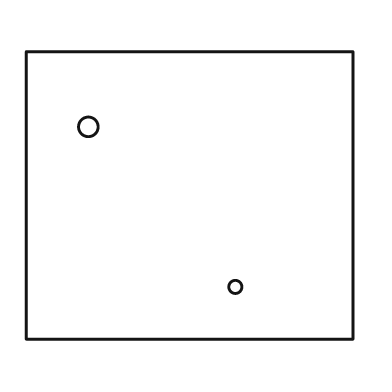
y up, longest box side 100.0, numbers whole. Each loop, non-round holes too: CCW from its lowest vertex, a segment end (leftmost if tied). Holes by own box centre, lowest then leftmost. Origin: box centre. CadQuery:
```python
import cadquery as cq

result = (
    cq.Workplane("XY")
    .moveTo(-50.0, -44.0)
    .lineTo(50.0, -44.0)
    .lineTo(50.0, 44.0)
    .lineTo(-50.0, 44.0)
    .close()
    .moveTo(14.0, -28.0)
    .circle(2.0)
    .moveTo(-31.0, 21.0)
    .circle(3.0)
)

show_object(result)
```